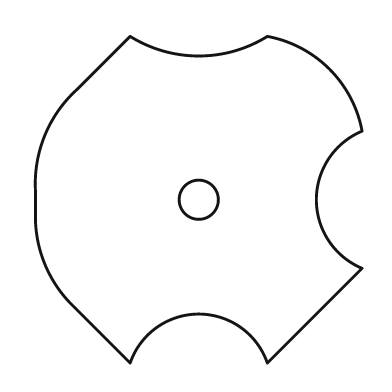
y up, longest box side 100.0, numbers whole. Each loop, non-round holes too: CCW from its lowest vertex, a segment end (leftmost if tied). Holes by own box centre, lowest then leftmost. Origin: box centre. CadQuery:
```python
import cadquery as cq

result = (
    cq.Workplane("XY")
    .moveTo(-21.0, -50.0)
    .threePointArc((0.0, -35.0), (21.0, -50.0))
    .lineTo(50.0, -21.0)
    .threePointArc((36.0, 0.0), (50.0, 21.0))
    .threePointArc((40.0, 40.0), (21.0, 50.0))
    .threePointArc((0.0, 44.0), (-21.0, 50.0))
    .lineTo(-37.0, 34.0)
    .threePointArc((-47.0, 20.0), (-50.0, 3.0))
    .lineTo(-50.0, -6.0)
    .threePointArc((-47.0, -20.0), (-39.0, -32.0))
    .close()
    .moveTo(0.0, 0.0)
    .circle(6.0)
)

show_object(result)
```